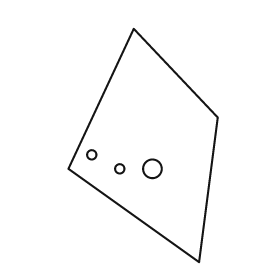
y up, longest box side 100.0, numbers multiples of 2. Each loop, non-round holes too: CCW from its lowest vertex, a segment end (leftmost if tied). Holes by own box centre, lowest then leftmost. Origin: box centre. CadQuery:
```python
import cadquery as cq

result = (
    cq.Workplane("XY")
    .moveTo(24.0, -50.0)
    .lineTo(32.0, 12.0)
    .lineTo(-4.0, 50.0)
    .lineTo(-32.0, -10.0)
    .close()
    .moveTo(-10.0, -10.0)
    .circle(2.0)
    .moveTo(4.0, -10.0)
    .circle(4.0)
    .moveTo(-22.0, -4.0)
    .circle(2.0)
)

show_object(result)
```